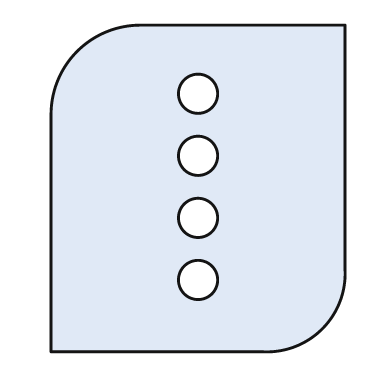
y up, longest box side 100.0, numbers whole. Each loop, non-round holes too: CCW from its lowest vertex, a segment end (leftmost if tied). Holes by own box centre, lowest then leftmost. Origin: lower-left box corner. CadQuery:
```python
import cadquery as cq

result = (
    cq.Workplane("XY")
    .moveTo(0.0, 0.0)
    .lineTo(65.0, 0.0)
    .threePointArc((83.0, 7.0), (90.0, 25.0))
    .lineTo(90.0, 100.0)
    .lineTo(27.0, 100.0)
    .threePointArc((8.0, 92.0), (0.0, 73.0))
    .close()
    .moveTo(45.0, 22.0)
    .circle(6.0)
    .moveTo(45.0, 41.0)
    .circle(6.0)
    .moveTo(45.0, 60.0)
    .circle(6.0)
    .moveTo(45.0, 79.0)
    .circle(6.0)
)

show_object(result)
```